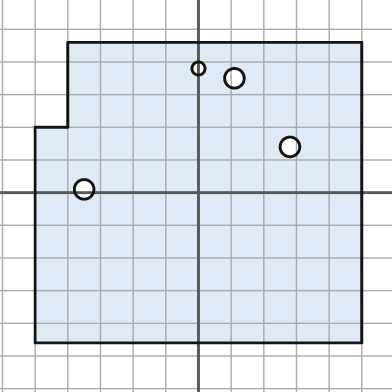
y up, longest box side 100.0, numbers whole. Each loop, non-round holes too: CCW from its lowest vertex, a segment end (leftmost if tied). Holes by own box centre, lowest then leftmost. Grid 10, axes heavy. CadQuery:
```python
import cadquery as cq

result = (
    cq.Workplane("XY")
    .moveTo(-50.0, -46.0)
    .lineTo(50.0, -46.0)
    .lineTo(50.0, 46.0)
    .lineTo(-40.0, 46.0)
    .lineTo(-40.0, 20.0)
    .lineTo(-50.0, 20.0)
    .close()
    .moveTo(-35.0, 1.0)
    .circle(3.0)
    .moveTo(28.0, 14.0)
    .circle(3.0)
    .moveTo(11.0, 35.0)
    .circle(3.0)
    .moveTo(0.0, 38.0)
    .circle(2.0)
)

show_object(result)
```